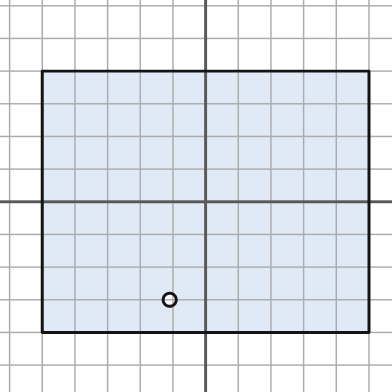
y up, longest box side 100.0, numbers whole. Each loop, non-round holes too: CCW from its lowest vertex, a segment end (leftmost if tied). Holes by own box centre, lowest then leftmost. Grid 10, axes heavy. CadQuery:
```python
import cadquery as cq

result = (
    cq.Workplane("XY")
    .moveTo(-50.0, -40.0)
    .lineTo(50.0, -40.0)
    .lineTo(50.0, 40.0)
    .lineTo(-50.0, 40.0)
    .close()
    .moveTo(-11.0, -30.0)
    .circle(2.0)
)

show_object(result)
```